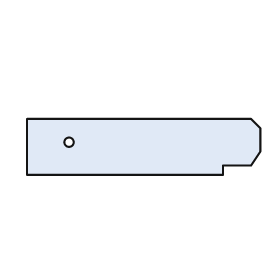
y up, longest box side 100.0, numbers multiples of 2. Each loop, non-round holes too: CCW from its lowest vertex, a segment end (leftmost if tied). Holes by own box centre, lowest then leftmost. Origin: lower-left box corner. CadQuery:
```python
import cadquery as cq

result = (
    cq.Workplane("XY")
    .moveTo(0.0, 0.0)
    .lineTo(84.0, 0.0)
    .lineTo(84.0, 4.0)
    .lineTo(96.0, 4.0)
    .lineTo(100.0, 10.0)
    .lineTo(100.0, 20.0)
    .lineTo(96.0, 24.0)
    .lineTo(0.0, 24.0)
    .close()
    .moveTo(18.0, 14.0)
    .circle(2.0)
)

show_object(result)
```